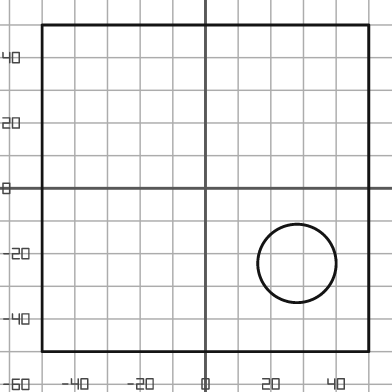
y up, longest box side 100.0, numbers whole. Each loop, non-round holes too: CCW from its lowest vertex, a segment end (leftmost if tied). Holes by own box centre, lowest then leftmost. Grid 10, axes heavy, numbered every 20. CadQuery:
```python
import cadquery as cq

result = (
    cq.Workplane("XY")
    .moveTo(-50.0, -50.0)
    .lineTo(50.0, -50.0)
    .lineTo(50.0, 50.0)
    .lineTo(-50.0, 50.0)
    .close()
    .moveTo(28.0, -23.0)
    .circle(12.0)
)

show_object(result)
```